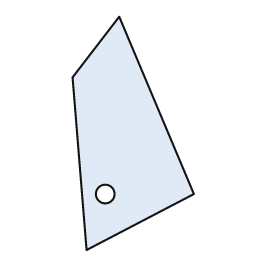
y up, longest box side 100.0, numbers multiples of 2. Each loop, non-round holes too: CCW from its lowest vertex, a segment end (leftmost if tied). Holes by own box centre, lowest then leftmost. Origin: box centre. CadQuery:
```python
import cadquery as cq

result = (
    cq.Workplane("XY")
    .moveTo(-20.0, -50.0)
    .lineTo(26.0, -26.0)
    .lineTo(-6.0, 50.0)
    .lineTo(-26.0, 24.0)
    .close()
    .moveTo(-12.0, -26.0)
    .circle(4.0)
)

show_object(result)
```